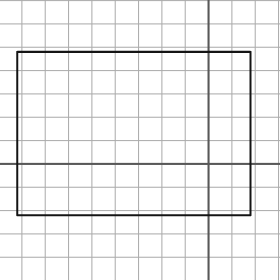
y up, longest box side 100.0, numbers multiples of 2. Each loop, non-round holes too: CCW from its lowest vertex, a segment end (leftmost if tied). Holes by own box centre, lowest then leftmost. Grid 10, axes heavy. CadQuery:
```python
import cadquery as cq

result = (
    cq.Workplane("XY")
    .moveTo(-82.0, -22.0)
    .lineTo(18.0, -22.0)
    .lineTo(18.0, 48.0)
    .lineTo(-82.0, 48.0)
    .close()
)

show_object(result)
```